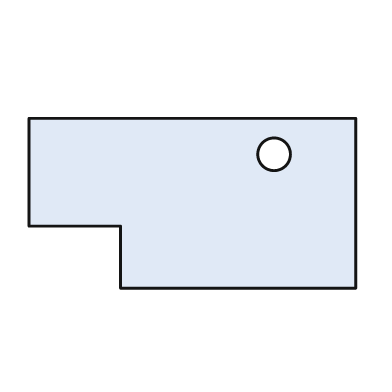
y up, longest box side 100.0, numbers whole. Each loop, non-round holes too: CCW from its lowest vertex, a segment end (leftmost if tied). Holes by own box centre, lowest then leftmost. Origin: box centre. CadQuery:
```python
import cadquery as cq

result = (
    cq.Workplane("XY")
    .moveTo(-22.0, -26.0)
    .lineTo(50.0, -26.0)
    .lineTo(50.0, 26.0)
    .lineTo(-50.0, 26.0)
    .lineTo(-50.0, -7.0)
    .lineTo(-22.0, -7.0)
    .close()
    .moveTo(25.0, 15.0)
    .circle(5.0)
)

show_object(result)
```